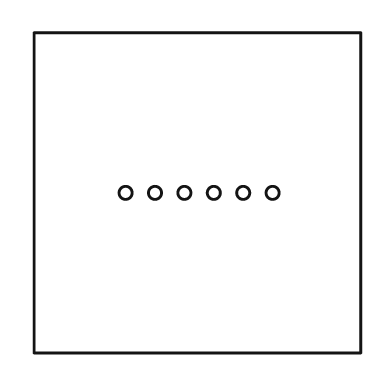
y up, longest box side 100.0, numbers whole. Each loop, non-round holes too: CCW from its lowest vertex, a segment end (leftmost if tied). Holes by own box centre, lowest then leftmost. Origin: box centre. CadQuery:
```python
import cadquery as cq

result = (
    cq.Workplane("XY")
    .moveTo(-50.0, -49.0)
    .lineTo(50.0, -49.0)
    .lineTo(50.0, 49.0)
    .lineTo(-50.0, 49.0)
    .close()
    .moveTo(-22.0, 0.0)
    .circle(2.0)
    .moveTo(-13.0, 0.0)
    .circle(2.0)
    .moveTo(-4.0, 0.0)
    .circle(2.0)
    .moveTo(5.0, 0.0)
    .circle(2.0)
    .moveTo(14.0, 0.0)
    .circle(2.0)
    .moveTo(23.0, 0.0)
    .circle(2.0)
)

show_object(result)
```